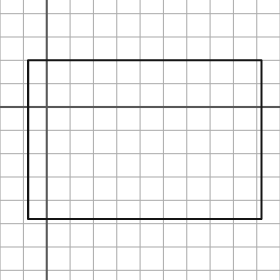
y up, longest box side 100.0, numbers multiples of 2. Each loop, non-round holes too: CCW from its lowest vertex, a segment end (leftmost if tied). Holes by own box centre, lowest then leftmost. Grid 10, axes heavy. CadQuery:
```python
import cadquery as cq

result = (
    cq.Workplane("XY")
    .moveTo(-8.0, -48.0)
    .lineTo(92.0, -48.0)
    .lineTo(92.0, 20.0)
    .lineTo(-8.0, 20.0)
    .close()
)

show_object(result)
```